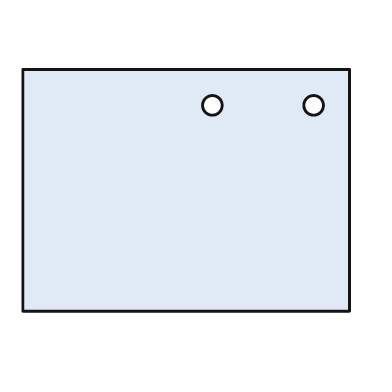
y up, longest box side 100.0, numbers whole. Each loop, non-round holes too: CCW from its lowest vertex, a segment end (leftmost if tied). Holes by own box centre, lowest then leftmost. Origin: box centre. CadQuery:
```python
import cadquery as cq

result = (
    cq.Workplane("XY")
    .moveTo(-50.0, -37.0)
    .lineTo(50.0, -37.0)
    .lineTo(50.0, 37.0)
    .lineTo(-50.0, 37.0)
    .close()
    .moveTo(8.0, 26.0)
    .circle(3.0)
    .moveTo(39.0, 26.0)
    .circle(3.0)
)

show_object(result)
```